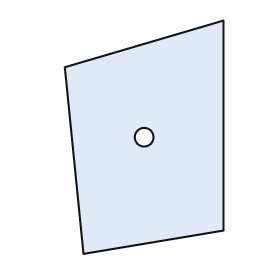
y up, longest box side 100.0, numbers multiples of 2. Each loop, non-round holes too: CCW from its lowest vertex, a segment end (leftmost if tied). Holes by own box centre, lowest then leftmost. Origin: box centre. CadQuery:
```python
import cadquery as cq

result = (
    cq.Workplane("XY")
    .moveTo(-26.0, -50.0)
    .lineTo(34.0, -40.0)
    .lineTo(34.0, 50.0)
    .lineTo(-34.0, 30.0)
    .close()
    .moveTo(0.0, 0.0)
    .circle(4.0)
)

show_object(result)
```